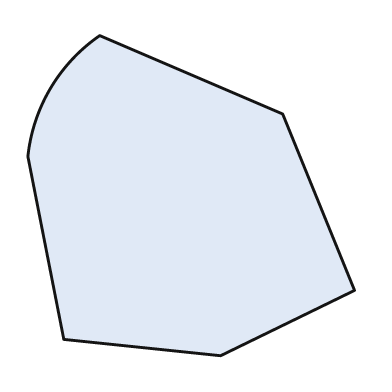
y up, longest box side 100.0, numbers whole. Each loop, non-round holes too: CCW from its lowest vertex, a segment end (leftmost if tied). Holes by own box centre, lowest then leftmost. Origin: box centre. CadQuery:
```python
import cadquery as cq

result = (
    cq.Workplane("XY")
    .moveTo(9.0, -49.0)
    .lineTo(50.0, -29.0)
    .lineTo(28.0, 25.0)
    .lineTo(-28.0, 49.0)
    .threePointArc((-43.0, 33.0), (-50.0, 12.0))
    .lineTo(-39.0, -44.0)
    .close()
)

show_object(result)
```